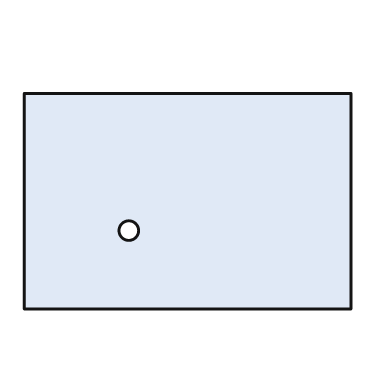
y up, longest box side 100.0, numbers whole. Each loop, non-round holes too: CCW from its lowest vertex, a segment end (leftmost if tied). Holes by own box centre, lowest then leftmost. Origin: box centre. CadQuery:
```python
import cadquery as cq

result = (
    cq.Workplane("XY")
    .moveTo(-50.0, -33.0)
    .lineTo(50.0, -33.0)
    .lineTo(50.0, 33.0)
    .lineTo(-50.0, 33.0)
    .close()
    .moveTo(-18.0, -9.0)
    .circle(3.0)
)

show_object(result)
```